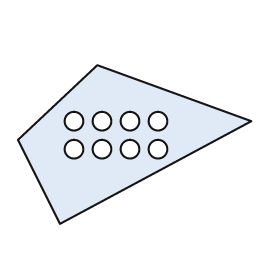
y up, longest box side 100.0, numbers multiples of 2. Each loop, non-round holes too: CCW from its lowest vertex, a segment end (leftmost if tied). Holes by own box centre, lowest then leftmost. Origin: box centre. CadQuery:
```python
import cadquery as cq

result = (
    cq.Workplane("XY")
    .moveTo(-32.0, -34.0)
    .lineTo(50.0, 10.0)
    .lineTo(-16.0, 34.0)
    .lineTo(-50.0, 2.0)
    .close()
    .moveTo(-26.0, -2.0)
    .circle(4.0)
    .moveTo(-14.0, -2.0)
    .circle(4.0)
    .moveTo(-2.0, -2.0)
    .circle(4.0)
    .moveTo(10.0, -2.0)
    .circle(4.0)
    .moveTo(-26.0, 10.0)
    .circle(4.0)
    .moveTo(-14.0, 10.0)
    .circle(4.0)
    .moveTo(-2.0, 10.0)
    .circle(4.0)
    .moveTo(10.0, 10.0)
    .circle(4.0)
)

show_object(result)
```